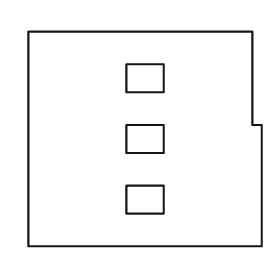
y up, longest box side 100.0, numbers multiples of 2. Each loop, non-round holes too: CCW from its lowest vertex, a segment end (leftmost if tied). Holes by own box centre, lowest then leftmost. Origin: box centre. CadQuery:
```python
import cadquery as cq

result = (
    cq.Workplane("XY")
    .moveTo(-50.0, -46.0)
    .lineTo(50.0, -46.0)
    .lineTo(50.0, 6.0)
    .lineTo(46.0, 6.0)
    .lineTo(46.0, 46.0)
    .lineTo(-50.0, 46.0)
    .close()
    .moveTo(-8.0, -32.0)
    .lineTo(8.0, -32.0)
    .lineTo(8.0, -20.0)
    .lineTo(-8.0, -20.0)
    .close()
    .moveTo(-8.0, -6.0)
    .lineTo(8.0, -6.0)
    .lineTo(8.0, 6.0)
    .lineTo(-8.0, 6.0)
    .close()
    .moveTo(-8.0, 20.0)
    .lineTo(8.0, 20.0)
    .lineTo(8.0, 32.0)
    .lineTo(-8.0, 32.0)
    .close()
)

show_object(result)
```